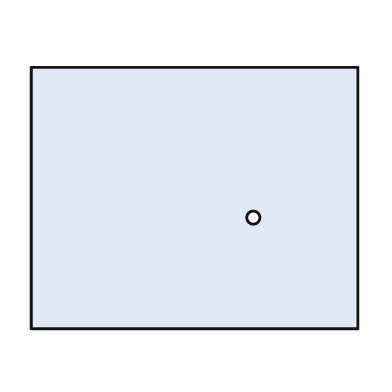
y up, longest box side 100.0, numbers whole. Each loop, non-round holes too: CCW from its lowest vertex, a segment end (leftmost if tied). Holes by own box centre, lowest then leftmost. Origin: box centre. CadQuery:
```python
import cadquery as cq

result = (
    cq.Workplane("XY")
    .moveTo(-50.0, -40.0)
    .lineTo(50.0, -40.0)
    .lineTo(50.0, 40.0)
    .lineTo(-50.0, 40.0)
    .close()
    .moveTo(18.0, -6.0)
    .circle(2.0)
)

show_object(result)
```